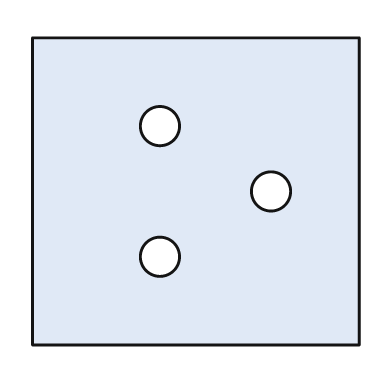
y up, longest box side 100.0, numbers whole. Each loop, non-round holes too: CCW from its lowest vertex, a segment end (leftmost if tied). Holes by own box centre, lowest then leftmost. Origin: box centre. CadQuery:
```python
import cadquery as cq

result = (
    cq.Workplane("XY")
    .moveTo(-50.0, -47.0)
    .lineTo(50.0, -47.0)
    .lineTo(50.0, 47.0)
    .lineTo(-50.0, 47.0)
    .close()
    .moveTo(-11.0, -20.0)
    .circle(6.0)
    .moveTo(23.0, 0.0)
    .circle(6.0)
    .moveTo(-11.0, 20.0)
    .circle(6.0)
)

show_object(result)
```